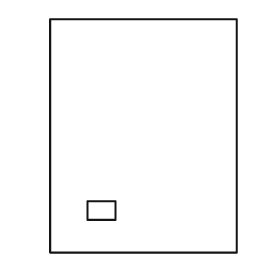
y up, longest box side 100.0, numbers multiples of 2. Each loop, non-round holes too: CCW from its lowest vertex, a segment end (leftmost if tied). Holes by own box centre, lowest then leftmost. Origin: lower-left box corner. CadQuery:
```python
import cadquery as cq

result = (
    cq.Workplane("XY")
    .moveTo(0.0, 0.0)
    .lineTo(80.0, 0.0)
    .lineTo(80.0, 100.0)
    .lineTo(0.0, 100.0)
    .close()
    .moveTo(16.0, 14.0)
    .lineTo(28.0, 14.0)
    .lineTo(28.0, 22.0)
    .lineTo(16.0, 22.0)
    .close()
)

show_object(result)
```